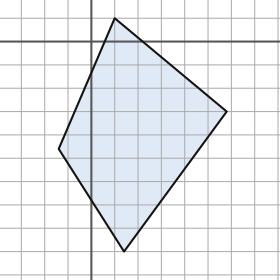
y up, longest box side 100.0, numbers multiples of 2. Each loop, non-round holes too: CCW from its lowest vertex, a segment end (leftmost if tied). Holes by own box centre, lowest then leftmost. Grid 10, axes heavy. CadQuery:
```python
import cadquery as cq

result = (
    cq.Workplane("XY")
    .moveTo(14.0, -90.0)
    .lineTo(58.0, -30.0)
    .lineTo(10.0, 10.0)
    .lineTo(-14.0, -46.0)
    .close()
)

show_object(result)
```